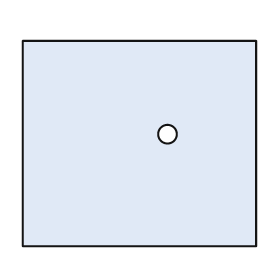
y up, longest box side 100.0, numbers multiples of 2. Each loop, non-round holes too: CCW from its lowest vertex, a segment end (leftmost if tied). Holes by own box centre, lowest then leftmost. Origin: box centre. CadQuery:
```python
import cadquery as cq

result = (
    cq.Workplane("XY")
    .moveTo(-50.0, -44.0)
    .lineTo(50.0, -44.0)
    .lineTo(50.0, 44.0)
    .lineTo(-50.0, 44.0)
    .close()
    .moveTo(12.0, 4.0)
    .circle(4.0)
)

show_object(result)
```